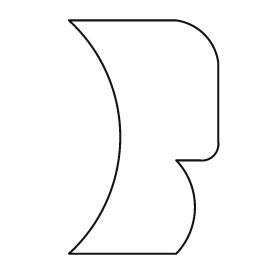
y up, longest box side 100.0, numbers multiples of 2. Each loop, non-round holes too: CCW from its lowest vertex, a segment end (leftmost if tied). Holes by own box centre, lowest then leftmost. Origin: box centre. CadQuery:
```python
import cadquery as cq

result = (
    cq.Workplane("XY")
    .moveTo(-32.0, -50.0)
    .lineTo(14.0, -50.0)
    .threePointArc((22.0, -30.0), (14.0, -10.0))
    .lineTo(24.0, -10.0)
    .threePointArc((30.0, -8.0), (32.0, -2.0))
    .lineTo(32.0, 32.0)
    .threePointArc((26.0, 44.0), (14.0, 50.0))
    .lineTo(-32.0, 50.0)
    .threePointArc((-10.0, 0.0), (-32.0, -50.0))
    .close()
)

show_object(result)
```